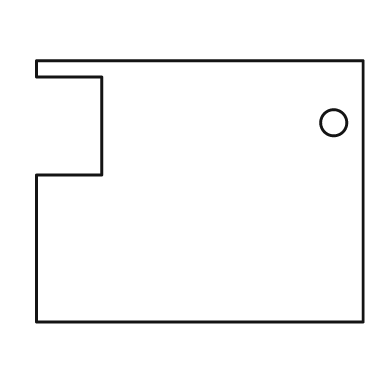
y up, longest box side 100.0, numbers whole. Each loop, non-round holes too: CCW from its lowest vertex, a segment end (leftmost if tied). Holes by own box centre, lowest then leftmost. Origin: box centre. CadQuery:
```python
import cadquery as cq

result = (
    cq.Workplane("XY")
    .moveTo(-50.0, -40.0)
    .lineTo(50.0, -40.0)
    .lineTo(50.0, 40.0)
    .lineTo(-50.0, 40.0)
    .lineTo(-50.0, 35.0)
    .lineTo(-30.0, 35.0)
    .lineTo(-30.0, 5.0)
    .lineTo(-50.0, 5.0)
    .close()
    .moveTo(41.0, 21.0)
    .circle(4.0)
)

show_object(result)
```